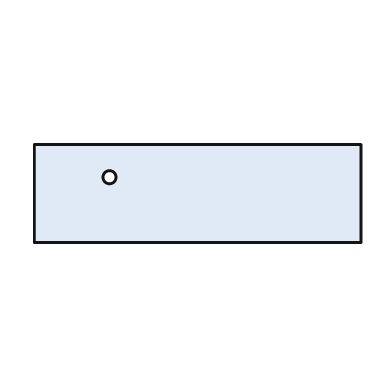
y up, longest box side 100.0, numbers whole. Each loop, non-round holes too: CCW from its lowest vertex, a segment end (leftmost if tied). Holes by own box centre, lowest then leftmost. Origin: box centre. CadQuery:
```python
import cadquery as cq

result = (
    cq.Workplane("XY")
    .moveTo(-50.0, -15.0)
    .lineTo(50.0, -15.0)
    .lineTo(50.0, 15.0)
    .lineTo(-50.0, 15.0)
    .close()
    .moveTo(-27.0, 5.0)
    .circle(2.0)
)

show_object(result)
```